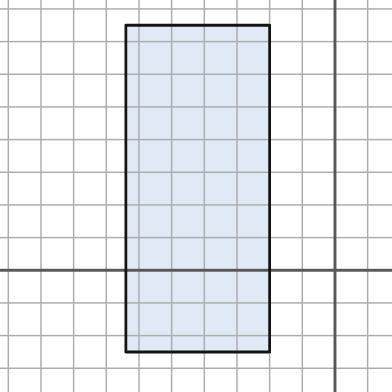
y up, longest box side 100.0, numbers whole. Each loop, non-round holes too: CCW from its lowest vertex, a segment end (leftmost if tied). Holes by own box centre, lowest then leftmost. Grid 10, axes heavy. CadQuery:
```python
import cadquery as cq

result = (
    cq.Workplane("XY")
    .moveTo(-64.0, -25.0)
    .lineTo(-20.0, -25.0)
    .lineTo(-20.0, 75.0)
    .lineTo(-64.0, 75.0)
    .close()
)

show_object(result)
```